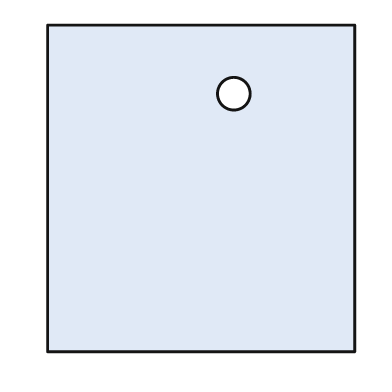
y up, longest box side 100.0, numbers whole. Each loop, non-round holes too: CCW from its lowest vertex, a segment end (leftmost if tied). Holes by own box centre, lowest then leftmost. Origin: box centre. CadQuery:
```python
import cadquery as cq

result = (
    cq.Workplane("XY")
    .moveTo(-47.0, -50.0)
    .lineTo(47.0, -50.0)
    .lineTo(47.0, 50.0)
    .lineTo(-47.0, 50.0)
    .close()
    .moveTo(10.0, 29.0)
    .circle(5.0)
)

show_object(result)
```